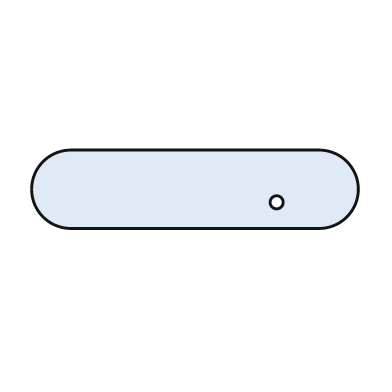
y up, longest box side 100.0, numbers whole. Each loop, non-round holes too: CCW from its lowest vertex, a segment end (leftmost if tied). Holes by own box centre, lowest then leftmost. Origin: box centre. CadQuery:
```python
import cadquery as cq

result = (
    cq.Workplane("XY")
    .moveTo(-38.0, -12.0)
    .lineTo(38.0, -12.0)
    .threePointArc((50.0, 0.0), (38.0, 12.0))
    .lineTo(-38.0, 12.0)
    .threePointArc((-50.0, 0.0), (-38.0, -12.0))
    .close()
    .moveTo(25.0, -4.0)
    .circle(2.0)
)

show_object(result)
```